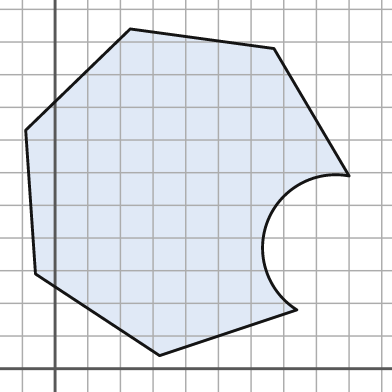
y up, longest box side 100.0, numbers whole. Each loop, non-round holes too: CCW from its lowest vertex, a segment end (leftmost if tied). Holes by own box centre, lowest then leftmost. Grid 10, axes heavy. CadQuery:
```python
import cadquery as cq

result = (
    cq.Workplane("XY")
    .moveTo(32.0, 4.0)
    .lineTo(74.0, 18.0)
    .threePointArc((65.0, 45.0), (90.0, 59.0))
    .lineTo(67.0, 98.0)
    .lineTo(23.0, 104.0)
    .lineTo(-9.0, 73.0)
    .lineTo(-6.0, 29.0)
    .close()
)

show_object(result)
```